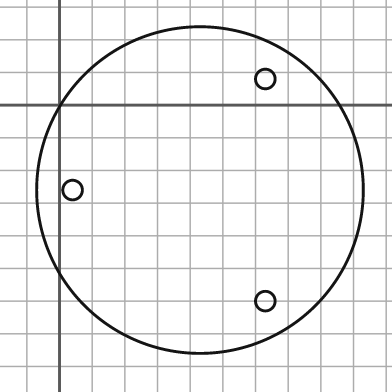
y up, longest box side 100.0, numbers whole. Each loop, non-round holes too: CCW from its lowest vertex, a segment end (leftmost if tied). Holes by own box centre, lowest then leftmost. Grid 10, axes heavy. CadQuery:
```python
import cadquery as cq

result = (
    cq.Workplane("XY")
    .moveTo(43.0, -26.0)
    .circle(50.0)
    .moveTo(63.0, -60.0)
    .circle(3.0)
    .moveTo(4.0, -26.0)
    .circle(3.0)
    .moveTo(63.0, 8.0)
    .circle(3.0)
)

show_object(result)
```